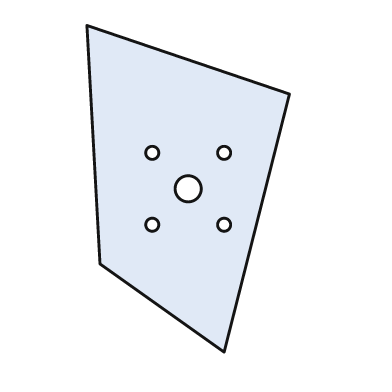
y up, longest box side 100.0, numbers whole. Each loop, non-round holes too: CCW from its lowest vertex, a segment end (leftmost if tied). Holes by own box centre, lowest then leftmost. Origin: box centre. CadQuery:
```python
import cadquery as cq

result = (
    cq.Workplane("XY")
    .moveTo(11.0, -50.0)
    .lineTo(31.0, 29.0)
    .lineTo(-31.0, 50.0)
    .lineTo(-27.0, -23.0)
    .close()
    .moveTo(-11.0, -11.0)
    .circle(2.0)
    .moveTo(11.0, -11.0)
    .circle(2.0)
    .moveTo(0.0, 0.0)
    .circle(4.0)
    .moveTo(-11.0, 11.0)
    .circle(2.0)
    .moveTo(11.0, 11.0)
    .circle(2.0)
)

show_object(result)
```